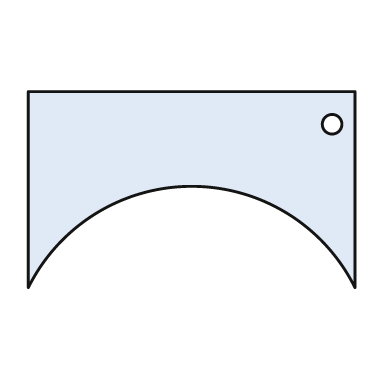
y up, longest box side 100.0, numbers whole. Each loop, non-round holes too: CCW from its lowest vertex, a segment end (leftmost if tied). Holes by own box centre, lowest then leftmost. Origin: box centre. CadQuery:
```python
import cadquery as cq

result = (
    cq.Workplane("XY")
    .moveTo(-50.0, -30.0)
    .threePointArc((0.0, 1.0), (50.0, -30.0))
    .lineTo(50.0, 30.0)
    .lineTo(-50.0, 30.0)
    .close()
    .moveTo(43.0, 20.0)
    .circle(3.0)
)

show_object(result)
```